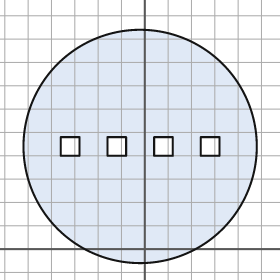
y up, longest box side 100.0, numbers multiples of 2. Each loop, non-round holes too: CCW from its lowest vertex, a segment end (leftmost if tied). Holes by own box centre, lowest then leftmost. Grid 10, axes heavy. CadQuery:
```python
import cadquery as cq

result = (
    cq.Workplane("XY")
    .moveTo(-2.0, 44.0)
    .circle(50.0)
    .moveTo(-36.0, 40.0)
    .lineTo(-28.0, 40.0)
    .lineTo(-28.0, 48.0)
    .lineTo(-36.0, 48.0)
    .close()
    .moveTo(-16.0, 40.0)
    .lineTo(-8.0, 40.0)
    .lineTo(-8.0, 48.0)
    .lineTo(-16.0, 48.0)
    .close()
    .moveTo(4.0, 40.0)
    .lineTo(12.0, 40.0)
    .lineTo(12.0, 48.0)
    .lineTo(4.0, 48.0)
    .close()
    .moveTo(24.0, 40.0)
    .lineTo(32.0, 40.0)
    .lineTo(32.0, 48.0)
    .lineTo(24.0, 48.0)
    .close()
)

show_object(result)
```